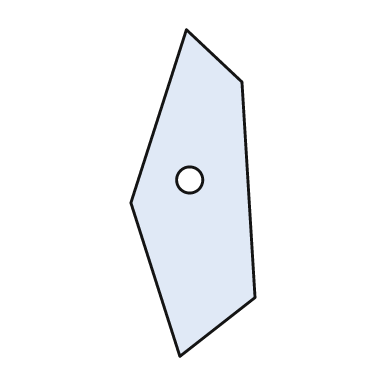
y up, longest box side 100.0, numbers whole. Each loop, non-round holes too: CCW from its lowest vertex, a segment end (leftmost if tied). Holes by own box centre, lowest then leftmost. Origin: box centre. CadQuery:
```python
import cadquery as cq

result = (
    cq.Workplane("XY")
    .moveTo(-4.0, -50.0)
    .lineTo(19.0, -32.0)
    .lineTo(15.0, 34.0)
    .lineTo(-2.0, 50.0)
    .lineTo(-19.0, -3.0)
    .close()
    .moveTo(-1.0, 4.0)
    .circle(4.0)
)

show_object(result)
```